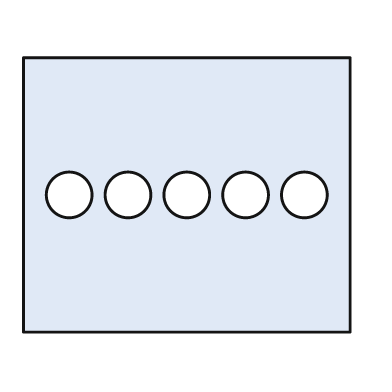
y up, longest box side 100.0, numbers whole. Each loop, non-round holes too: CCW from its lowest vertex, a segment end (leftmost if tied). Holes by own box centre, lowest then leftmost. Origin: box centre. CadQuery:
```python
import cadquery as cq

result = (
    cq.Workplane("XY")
    .moveTo(-50.0, -42.0)
    .lineTo(50.0, -42.0)
    .lineTo(50.0, 42.0)
    .lineTo(-50.0, 42.0)
    .close()
    .moveTo(-36.0, 0.0)
    .circle(7.0)
    .moveTo(-18.0, 0.0)
    .circle(7.0)
    .moveTo(0.0, 0.0)
    .circle(7.0)
    .moveTo(18.0, 0.0)
    .circle(7.0)
    .moveTo(36.0, 0.0)
    .circle(7.0)
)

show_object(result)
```